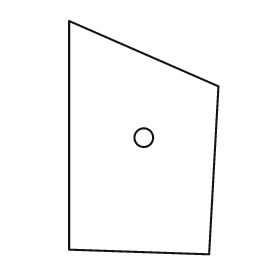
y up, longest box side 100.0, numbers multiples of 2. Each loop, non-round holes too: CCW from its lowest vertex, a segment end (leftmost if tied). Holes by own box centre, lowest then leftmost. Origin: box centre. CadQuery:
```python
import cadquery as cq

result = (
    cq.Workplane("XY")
    .moveTo(28.0, -50.0)
    .lineTo(32.0, 22.0)
    .lineTo(-32.0, 50.0)
    .lineTo(-32.0, -48.0)
    .close()
    .moveTo(0.0, 0.0)
    .circle(4.0)
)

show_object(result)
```